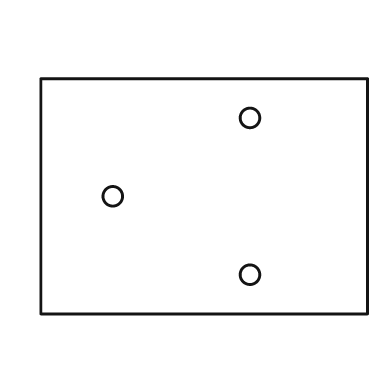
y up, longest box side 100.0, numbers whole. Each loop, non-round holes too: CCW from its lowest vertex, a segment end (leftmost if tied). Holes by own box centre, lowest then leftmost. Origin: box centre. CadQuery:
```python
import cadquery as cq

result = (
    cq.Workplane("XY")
    .moveTo(-50.0, -36.0)
    .lineTo(50.0, -36.0)
    .lineTo(50.0, 36.0)
    .lineTo(-50.0, 36.0)
    .close()
    .moveTo(14.0, -24.0)
    .circle(3.0)
    .moveTo(-28.0, 0.0)
    .circle(3.0)
    .moveTo(14.0, 24.0)
    .circle(3.0)
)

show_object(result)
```